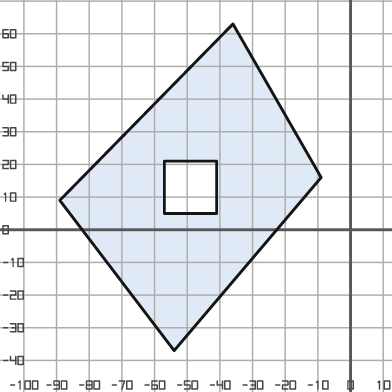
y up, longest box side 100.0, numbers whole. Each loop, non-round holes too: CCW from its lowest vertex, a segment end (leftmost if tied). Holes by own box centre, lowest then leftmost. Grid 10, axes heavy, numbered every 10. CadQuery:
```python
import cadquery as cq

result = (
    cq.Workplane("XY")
    .moveTo(-54.0, -37.0)
    .lineTo(-9.0, 16.0)
    .lineTo(-36.0, 63.0)
    .lineTo(-89.0, 9.0)
    .close()
    .moveTo(-57.0, 5.0)
    .lineTo(-41.0, 5.0)
    .lineTo(-41.0, 21.0)
    .lineTo(-57.0, 21.0)
    .close()
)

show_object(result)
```